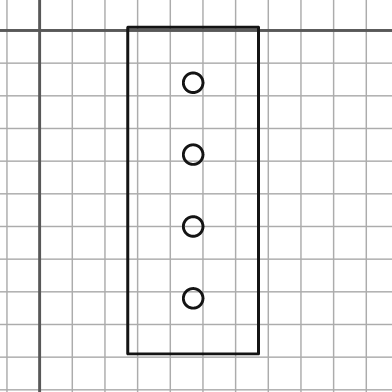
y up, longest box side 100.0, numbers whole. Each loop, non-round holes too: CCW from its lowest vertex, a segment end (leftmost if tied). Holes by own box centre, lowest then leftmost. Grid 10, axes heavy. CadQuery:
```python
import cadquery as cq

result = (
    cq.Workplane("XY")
    .moveTo(27.0, -99.0)
    .lineTo(67.0, -99.0)
    .lineTo(67.0, 1.0)
    .lineTo(27.0, 1.0)
    .close()
    .moveTo(47.0, -82.0)
    .circle(3.0)
    .moveTo(47.0, -60.0)
    .circle(3.0)
    .moveTo(47.0, -38.0)
    .circle(3.0)
    .moveTo(47.0, -16.0)
    .circle(3.0)
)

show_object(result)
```